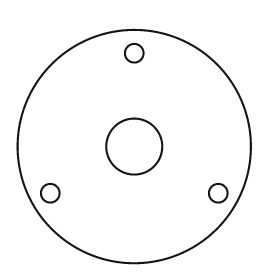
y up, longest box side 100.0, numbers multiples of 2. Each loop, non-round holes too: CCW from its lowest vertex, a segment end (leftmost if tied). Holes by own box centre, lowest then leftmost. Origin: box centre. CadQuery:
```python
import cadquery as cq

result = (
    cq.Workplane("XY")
    .moveTo(0.0, 0.0)
    .circle(50.0)
    .moveTo(-36.0, -20.0)
    .circle(4.0)
    .moveTo(36.0, -20.0)
    .circle(4.0)
    .moveTo(0.0, 0.0)
    .circle(12.0)
    .moveTo(0.0, 40.0)
    .circle(4.0)
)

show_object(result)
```